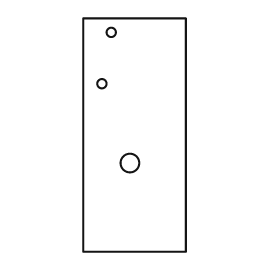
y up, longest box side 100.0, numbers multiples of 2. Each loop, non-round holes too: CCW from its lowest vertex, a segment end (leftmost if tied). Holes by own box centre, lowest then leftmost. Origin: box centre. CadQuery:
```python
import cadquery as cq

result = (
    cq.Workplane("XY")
    .moveTo(-22.0, -50.0)
    .lineTo(22.0, -50.0)
    .lineTo(22.0, 50.0)
    .lineTo(-22.0, 50.0)
    .close()
    .moveTo(-2.0, -12.0)
    .circle(4.0)
    .moveTo(-14.0, 22.0)
    .circle(2.0)
    .moveTo(-10.0, 44.0)
    .circle(2.0)
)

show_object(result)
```